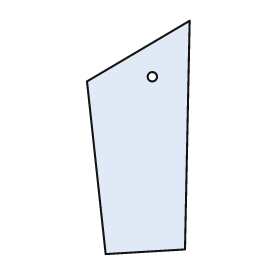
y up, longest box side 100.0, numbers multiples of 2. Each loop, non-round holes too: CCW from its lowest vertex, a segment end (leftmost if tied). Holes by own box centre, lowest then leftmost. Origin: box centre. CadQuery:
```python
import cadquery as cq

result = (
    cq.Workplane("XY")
    .moveTo(-14.0, -50.0)
    .lineTo(20.0, -48.0)
    .lineTo(22.0, 50.0)
    .lineTo(-22.0, 24.0)
    .close()
    .moveTo(6.0, 26.0)
    .circle(2.0)
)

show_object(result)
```